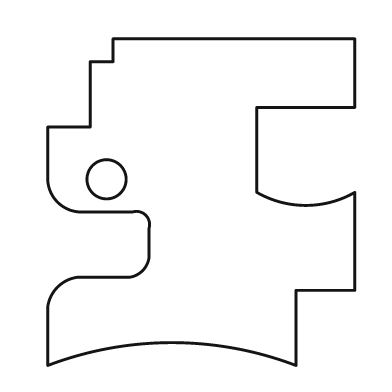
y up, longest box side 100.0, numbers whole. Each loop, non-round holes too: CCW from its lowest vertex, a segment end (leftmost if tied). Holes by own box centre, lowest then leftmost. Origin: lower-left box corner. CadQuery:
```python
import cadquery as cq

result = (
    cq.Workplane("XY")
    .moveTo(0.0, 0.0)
    .threePointArc((38.0, 7.0), (76.0, 0.0))
    .lineTo(76.0, 23.0)
    .lineTo(94.0, 23.0)
    .lineTo(94.0, 53.0)
    .threePointArc((79.0, 49.0), (64.0, 53.0))
    .lineTo(64.0, 79.0)
    .lineTo(94.0, 79.0)
    .lineTo(94.0, 100.0)
    .lineTo(20.0, 100.0)
    .lineTo(20.0, 93.0)
    .lineTo(13.0, 93.0)
    .lineTo(13.0, 73.0)
    .lineTo(0.0, 73.0)
    .lineTo(0.0, 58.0)
    .threePointArc((3.0, 50.0), (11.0, 47.0))
    .lineTo(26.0, 47.0)
    .threePointArc((30.0, 46.0), (31.0, 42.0))
    .lineTo(31.0, 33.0)
    .threePointArc((29.0, 29.0), (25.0, 27.0))
    .lineTo(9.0, 27.0)
    .threePointArc((3.0, 24.0), (0.0, 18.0))
    .close()
    .moveTo(18.0, 57.0)
    .circle(6.0)
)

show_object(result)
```